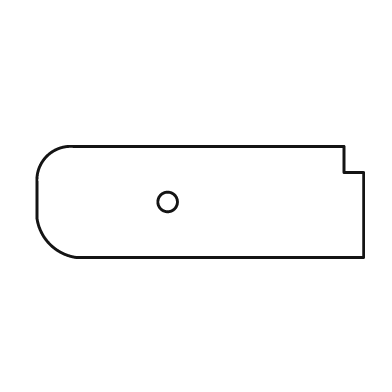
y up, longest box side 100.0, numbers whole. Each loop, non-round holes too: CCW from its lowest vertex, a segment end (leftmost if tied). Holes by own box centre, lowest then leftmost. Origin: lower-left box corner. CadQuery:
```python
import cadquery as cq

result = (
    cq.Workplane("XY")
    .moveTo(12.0, 0.0)
    .lineTo(100.0, 0.0)
    .lineTo(100.0, 26.0)
    .lineTo(94.0, 26.0)
    .lineTo(94.0, 34.0)
    .lineTo(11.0, 34.0)
    .threePointArc((3.0, 31.0), (0.0, 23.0))
    .lineTo(0.0, 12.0)
    .threePointArc((4.0, 4.0), (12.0, 0.0))
    .close()
    .moveTo(40.0, 17.0)
    .circle(3.0)
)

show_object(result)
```